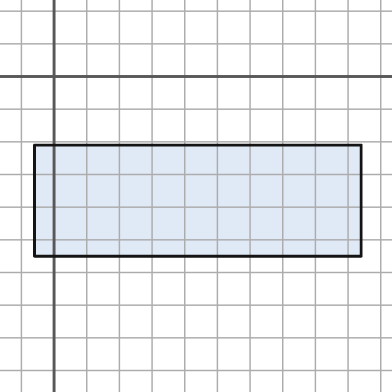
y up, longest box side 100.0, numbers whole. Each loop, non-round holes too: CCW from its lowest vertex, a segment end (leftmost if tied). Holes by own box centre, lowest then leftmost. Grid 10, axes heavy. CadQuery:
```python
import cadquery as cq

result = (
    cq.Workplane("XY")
    .moveTo(-6.0, -55.0)
    .lineTo(94.0, -55.0)
    .lineTo(94.0, -21.0)
    .lineTo(-6.0, -21.0)
    .close()
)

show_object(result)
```